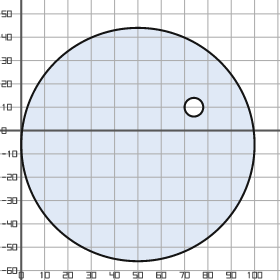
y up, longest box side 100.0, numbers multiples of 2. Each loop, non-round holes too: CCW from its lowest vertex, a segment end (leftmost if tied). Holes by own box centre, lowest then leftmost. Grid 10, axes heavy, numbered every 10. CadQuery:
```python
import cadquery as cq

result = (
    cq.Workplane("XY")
    .moveTo(50.0, -6.0)
    .circle(50.0)
    .moveTo(74.0, 10.0)
    .circle(4.0)
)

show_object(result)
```